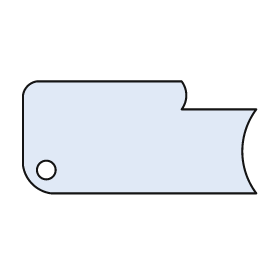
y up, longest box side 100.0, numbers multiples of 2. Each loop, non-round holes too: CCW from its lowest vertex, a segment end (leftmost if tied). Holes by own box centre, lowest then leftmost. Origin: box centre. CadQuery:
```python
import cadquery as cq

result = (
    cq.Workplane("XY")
    .moveTo(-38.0, -24.0)
    .lineTo(50.0, -24.0)
    .threePointArc((44.0, -6.0), (50.0, 12.0))
    .lineTo(18.0, 12.0)
    .threePointArc((20.0, 18.0), (18.0, 24.0))
    .lineTo(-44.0, 24.0)
    .threePointArc((-48.0, 22.0), (-50.0, 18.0))
    .lineTo(-50.0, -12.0)
    .threePointArc((-46.0, -20.0), (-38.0, -24.0))
    .close()
    .moveTo(-40.0, -14.0)
    .circle(4.0)
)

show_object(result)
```